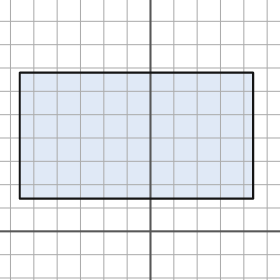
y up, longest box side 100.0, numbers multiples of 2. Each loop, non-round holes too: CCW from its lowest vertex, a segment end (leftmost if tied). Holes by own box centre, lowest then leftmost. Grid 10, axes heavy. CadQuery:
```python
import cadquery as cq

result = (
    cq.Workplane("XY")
    .moveTo(-56.0, 14.0)
    .lineTo(44.0, 14.0)
    .lineTo(44.0, 68.0)
    .lineTo(-56.0, 68.0)
    .close()
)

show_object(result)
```